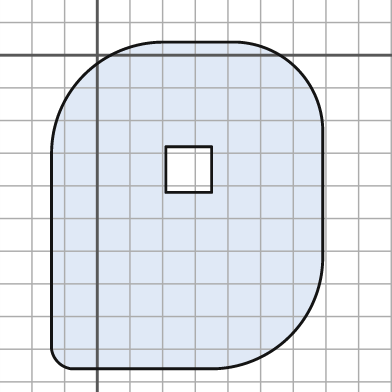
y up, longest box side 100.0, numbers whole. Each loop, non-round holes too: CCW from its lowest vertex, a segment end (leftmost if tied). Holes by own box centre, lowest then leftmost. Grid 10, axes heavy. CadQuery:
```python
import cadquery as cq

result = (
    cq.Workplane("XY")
    .moveTo(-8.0, -96.0)
    .lineTo(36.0, -96.0)
    .threePointArc((59.0, -86.0), (69.0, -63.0))
    .lineTo(69.0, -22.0)
    .threePointArc((61.0, -4.0), (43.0, 4.0))
    .lineTo(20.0, 4.0)
    .threePointArc((-4.0, -6.0), (-14.0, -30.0))
    .lineTo(-14.0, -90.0)
    .threePointArc((-12.0, -94.0), (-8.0, -96.0))
    .close()
    .moveTo(21.0, -42.0)
    .lineTo(35.0, -42.0)
    .lineTo(35.0, -28.0)
    .lineTo(21.0, -28.0)
    .close()
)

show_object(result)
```